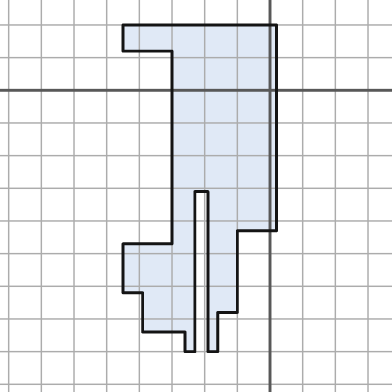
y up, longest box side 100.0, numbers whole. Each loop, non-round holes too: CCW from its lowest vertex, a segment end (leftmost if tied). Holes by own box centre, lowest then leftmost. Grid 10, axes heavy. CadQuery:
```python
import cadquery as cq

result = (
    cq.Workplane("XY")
    .moveTo(-26.0, -80.0)
    .lineTo(-23.0, -80.0)
    .lineTo(-23.0, -31.0)
    .lineTo(-19.0, -31.0)
    .lineTo(-19.0, -80.0)
    .lineTo(-16.0, -80.0)
    .lineTo(-16.0, -68.0)
    .lineTo(-10.0, -68.0)
    .lineTo(-10.0, -43.0)
    .lineTo(2.0, -43.0)
    .lineTo(2.0, 20.0)
    .lineTo(-45.0, 20.0)
    .lineTo(-45.0, 12.0)
    .lineTo(-30.0, 12.0)
    .lineTo(-30.0, -47.0)
    .lineTo(-45.0, -47.0)
    .lineTo(-45.0, -62.0)
    .lineTo(-39.0, -62.0)
    .lineTo(-39.0, -74.0)
    .lineTo(-26.0, -74.0)
    .close()
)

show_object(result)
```